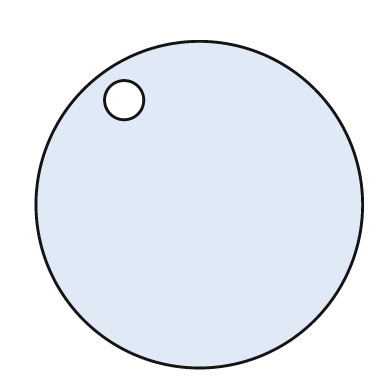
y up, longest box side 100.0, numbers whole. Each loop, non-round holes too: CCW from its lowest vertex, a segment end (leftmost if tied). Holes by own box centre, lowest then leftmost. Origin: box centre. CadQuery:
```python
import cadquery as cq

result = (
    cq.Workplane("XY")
    .moveTo(0.0, 0.0)
    .circle(50.0)
    .moveTo(-23.0, 32.0)
    .circle(6.0)
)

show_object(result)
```